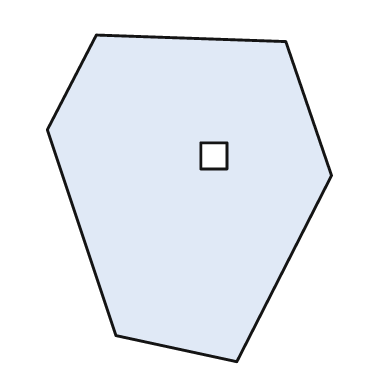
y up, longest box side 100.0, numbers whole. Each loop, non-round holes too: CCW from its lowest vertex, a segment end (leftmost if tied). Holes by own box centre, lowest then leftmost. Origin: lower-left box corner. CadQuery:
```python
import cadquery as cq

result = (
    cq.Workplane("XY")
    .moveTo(58.0, 0.0)
    .lineTo(87.0, 57.0)
    .lineTo(73.0, 98.0)
    .lineTo(15.0, 100.0)
    .lineTo(0.0, 71.0)
    .lineTo(21.0, 8.0)
    .close()
    .moveTo(47.0, 59.0)
    .lineTo(55.0, 59.0)
    .lineTo(55.0, 67.0)
    .lineTo(47.0, 67.0)
    .close()
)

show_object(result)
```